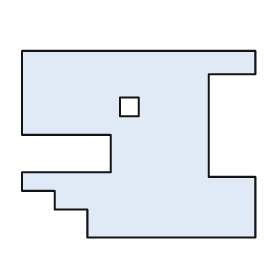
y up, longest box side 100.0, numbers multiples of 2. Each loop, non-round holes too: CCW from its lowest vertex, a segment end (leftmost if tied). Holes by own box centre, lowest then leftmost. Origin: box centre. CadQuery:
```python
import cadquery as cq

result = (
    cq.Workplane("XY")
    .moveTo(-22.0, -40.0)
    .lineTo(50.0, -40.0)
    .lineTo(50.0, -14.0)
    .lineTo(30.0, -14.0)
    .lineTo(30.0, 30.0)
    .lineTo(50.0, 30.0)
    .lineTo(50.0, 40.0)
    .lineTo(-50.0, 40.0)
    .lineTo(-50.0, 4.0)
    .lineTo(-12.0, 4.0)
    .lineTo(-12.0, -12.0)
    .lineTo(-50.0, -12.0)
    .lineTo(-50.0, -20.0)
    .lineTo(-36.0, -20.0)
    .lineTo(-36.0, -28.0)
    .lineTo(-22.0, -28.0)
    .close()
    .moveTo(-8.0, 12.0)
    .lineTo(0.0, 12.0)
    .lineTo(0.0, 20.0)
    .lineTo(-8.0, 20.0)
    .close()
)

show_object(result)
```